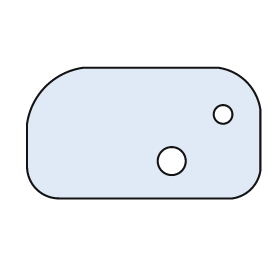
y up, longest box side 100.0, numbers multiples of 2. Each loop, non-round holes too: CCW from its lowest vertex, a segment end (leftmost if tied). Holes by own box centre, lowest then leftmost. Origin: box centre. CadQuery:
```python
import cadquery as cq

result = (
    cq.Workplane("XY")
    .moveTo(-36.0, -28.0)
    .lineTo(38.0, -28.0)
    .threePointArc((46.0, -24.0), (50.0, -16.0))
    .lineTo(50.0, 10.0)
    .threePointArc((44.0, 22.0), (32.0, 28.0))
    .lineTo(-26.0, 28.0)
    .threePointArc((-42.0, 20.0), (-50.0, 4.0))
    .lineTo(-50.0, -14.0)
    .threePointArc((-46.0, -24.0), (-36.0, -28.0))
    .close()
    .moveTo(12.0, -12.0)
    .circle(6.0)
    .moveTo(34.0, 8.0)
    .circle(4.0)
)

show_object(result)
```